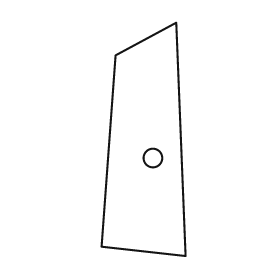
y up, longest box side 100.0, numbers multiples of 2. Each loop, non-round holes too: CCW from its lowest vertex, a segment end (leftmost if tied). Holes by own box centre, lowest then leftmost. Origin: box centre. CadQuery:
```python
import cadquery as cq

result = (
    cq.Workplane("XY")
    .moveTo(18.0, -50.0)
    .lineTo(14.0, 50.0)
    .lineTo(-12.0, 36.0)
    .lineTo(-18.0, -46.0)
    .close()
    .moveTo(4.0, -8.0)
    .circle(4.0)
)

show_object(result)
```